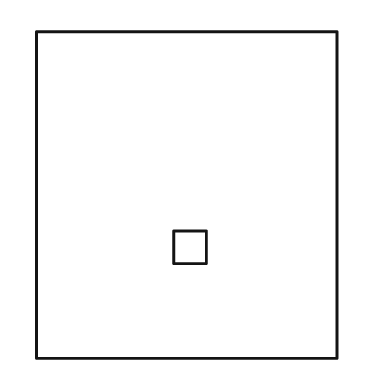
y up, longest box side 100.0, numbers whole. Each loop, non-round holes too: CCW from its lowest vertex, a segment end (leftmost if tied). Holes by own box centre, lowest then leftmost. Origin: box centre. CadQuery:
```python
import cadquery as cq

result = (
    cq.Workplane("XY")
    .moveTo(-46.0, -50.0)
    .lineTo(46.0, -50.0)
    .lineTo(46.0, 50.0)
    .lineTo(-46.0, 50.0)
    .close()
    .moveTo(-4.0, -21.0)
    .lineTo(6.0, -21.0)
    .lineTo(6.0, -11.0)
    .lineTo(-4.0, -11.0)
    .close()
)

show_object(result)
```